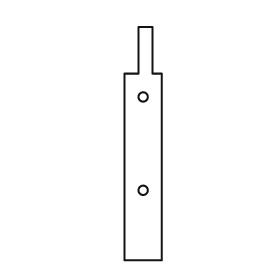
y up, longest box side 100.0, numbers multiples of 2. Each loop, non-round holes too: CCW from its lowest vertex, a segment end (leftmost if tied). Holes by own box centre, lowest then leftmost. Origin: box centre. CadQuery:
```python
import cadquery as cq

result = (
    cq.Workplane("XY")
    .moveTo(-8.0, -50.0)
    .lineTo(8.0, -50.0)
    .lineTo(8.0, 30.0)
    .lineTo(4.0, 30.0)
    .lineTo(4.0, 50.0)
    .lineTo(-2.0, 50.0)
    .lineTo(-2.0, 30.0)
    .lineTo(-8.0, 30.0)
    .close()
    .moveTo(0.0, -20.0)
    .circle(2.0)
    .moveTo(0.0, 20.0)
    .circle(2.0)
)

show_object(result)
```